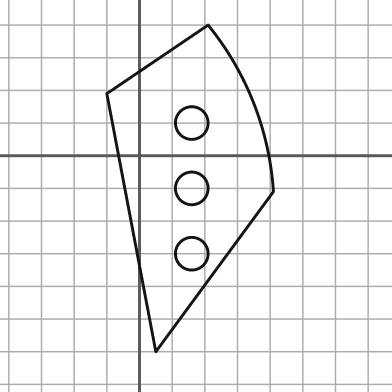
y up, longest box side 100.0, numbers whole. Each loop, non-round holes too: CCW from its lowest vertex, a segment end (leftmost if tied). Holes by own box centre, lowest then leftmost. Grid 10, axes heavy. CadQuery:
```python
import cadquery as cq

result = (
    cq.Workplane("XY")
    .moveTo(5.0, -60.0)
    .lineTo(41.0, -11.0)
    .threePointArc((35.0, 16.0), (21.0, 40.0))
    .lineTo(-10.0, 19.0)
    .close()
    .moveTo(16.0, -30.0)
    .circle(5.0)
    .moveTo(16.0, -10.0)
    .circle(5.0)
    .moveTo(16.0, 10.0)
    .circle(5.0)
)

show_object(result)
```